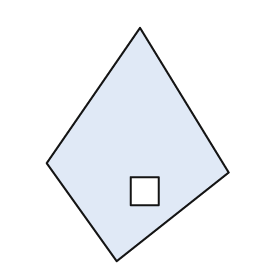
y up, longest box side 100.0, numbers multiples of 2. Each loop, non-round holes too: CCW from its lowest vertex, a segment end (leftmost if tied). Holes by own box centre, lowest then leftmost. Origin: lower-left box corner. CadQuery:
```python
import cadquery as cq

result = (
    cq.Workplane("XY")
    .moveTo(30.0, 0.0)
    .lineTo(78.0, 38.0)
    .lineTo(40.0, 100.0)
    .lineTo(0.0, 42.0)
    .close()
    .moveTo(36.0, 24.0)
    .lineTo(48.0, 24.0)
    .lineTo(48.0, 36.0)
    .lineTo(36.0, 36.0)
    .close()
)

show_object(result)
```